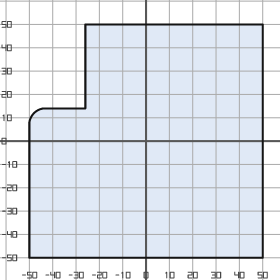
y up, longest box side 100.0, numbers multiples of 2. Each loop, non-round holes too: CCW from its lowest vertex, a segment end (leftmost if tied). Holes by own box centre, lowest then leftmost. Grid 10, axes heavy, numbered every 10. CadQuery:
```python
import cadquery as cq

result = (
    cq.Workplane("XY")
    .moveTo(-50.0, -50.0)
    .lineTo(50.0, -50.0)
    .lineTo(50.0, 50.0)
    .lineTo(-26.0, 50.0)
    .lineTo(-26.0, 14.0)
    .lineTo(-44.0, 14.0)
    .threePointArc((-48.0, 12.0), (-50.0, 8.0))
    .close()
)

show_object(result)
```